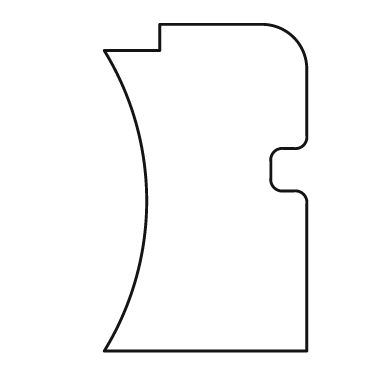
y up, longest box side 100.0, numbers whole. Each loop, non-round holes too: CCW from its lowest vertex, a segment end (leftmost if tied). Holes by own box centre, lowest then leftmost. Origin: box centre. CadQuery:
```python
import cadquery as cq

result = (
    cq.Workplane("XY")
    .moveTo(-31.0, -50.0)
    .lineTo(31.0, -50.0)
    .lineTo(31.0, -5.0)
    .threePointArc((30.0, -2.0), (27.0, -1.0))
    .lineTo(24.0, -1.0)
    .threePointArc((21.0, 0.0), (20.0, 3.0))
    .lineTo(20.0, 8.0)
    .threePointArc((21.0, 11.0), (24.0, 12.0))
    .lineTo(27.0, 12.0)
    .threePointArc((30.0, 13.0), (31.0, 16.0))
    .lineTo(31.0, 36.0)
    .threePointArc((27.0, 46.0), (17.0, 50.0))
    .lineTo(-14.0, 50.0)
    .lineTo(-14.0, 42.0)
    .lineTo(-31.0, 42.0)
    .threePointArc((-18.0, -4.0), (-31.0, -50.0))
    .close()
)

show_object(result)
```